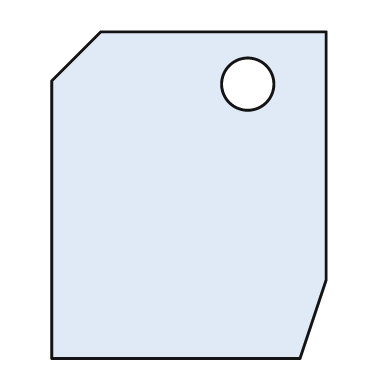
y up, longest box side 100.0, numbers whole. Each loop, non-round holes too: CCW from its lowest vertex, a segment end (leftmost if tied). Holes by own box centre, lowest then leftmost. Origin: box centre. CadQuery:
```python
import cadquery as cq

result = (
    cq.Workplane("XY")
    .moveTo(-42.0, -50.0)
    .lineTo(34.0, -50.0)
    .lineTo(42.0, -26.0)
    .lineTo(42.0, 50.0)
    .lineTo(-27.0, 50.0)
    .lineTo(-42.0, 35.0)
    .close()
    .moveTo(18.0, 34.0)
    .circle(8.0)
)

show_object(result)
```